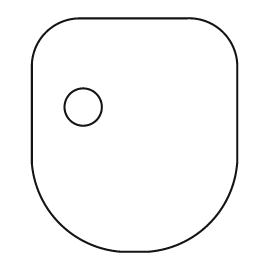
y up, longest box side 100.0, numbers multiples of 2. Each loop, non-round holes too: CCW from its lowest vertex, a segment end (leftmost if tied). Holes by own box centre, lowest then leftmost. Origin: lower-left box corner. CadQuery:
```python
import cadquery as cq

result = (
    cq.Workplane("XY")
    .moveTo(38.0, 0.0)
    .lineTo(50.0, 0.0)
    .threePointArc((76.0, 12.0), (88.0, 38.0))
    .lineTo(88.0, 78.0)
    .threePointArc((82.0, 94.0), (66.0, 100.0))
    .lineTo(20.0, 100.0)
    .threePointArc((6.0, 94.0), (0.0, 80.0))
    .lineTo(0.0, 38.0)
    .threePointArc((12.0, 12.0), (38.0, 0.0))
    .close()
    .moveTo(22.0, 62.0)
    .circle(8.0)
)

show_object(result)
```